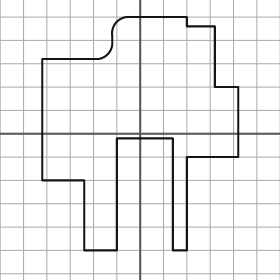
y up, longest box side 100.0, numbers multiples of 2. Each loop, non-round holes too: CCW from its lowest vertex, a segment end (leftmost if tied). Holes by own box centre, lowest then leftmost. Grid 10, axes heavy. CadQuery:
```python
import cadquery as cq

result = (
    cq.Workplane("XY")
    .moveTo(-24.0, -50.0)
    .lineTo(-10.0, -50.0)
    .lineTo(-10.0, -2.0)
    .lineTo(14.0, -2.0)
    .lineTo(14.0, -50.0)
    .lineTo(20.0, -50.0)
    .lineTo(20.0, -10.0)
    .lineTo(42.0, -10.0)
    .lineTo(42.0, 20.0)
    .lineTo(32.0, 20.0)
    .lineTo(32.0, 46.0)
    .lineTo(20.0, 46.0)
    .lineTo(20.0, 50.0)
    .lineTo(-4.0, 50.0)
    .threePointArc((-10.0, 48.0), (-12.0, 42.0))
    .lineTo(-12.0, 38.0)
    .threePointArc((-14.0, 34.0), (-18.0, 32.0))
    .lineTo(-42.0, 32.0)
    .lineTo(-42.0, -20.0)
    .lineTo(-24.0, -20.0)
    .close()
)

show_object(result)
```